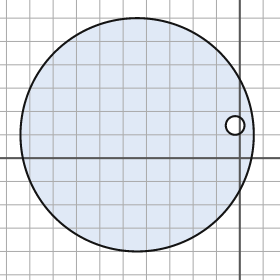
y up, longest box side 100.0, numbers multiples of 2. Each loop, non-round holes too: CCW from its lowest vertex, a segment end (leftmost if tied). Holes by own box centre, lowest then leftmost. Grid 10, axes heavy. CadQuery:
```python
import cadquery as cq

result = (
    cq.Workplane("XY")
    .moveTo(-44.0, 10.0)
    .circle(50.0)
    .moveTo(-2.0, 14.0)
    .circle(4.0)
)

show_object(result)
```